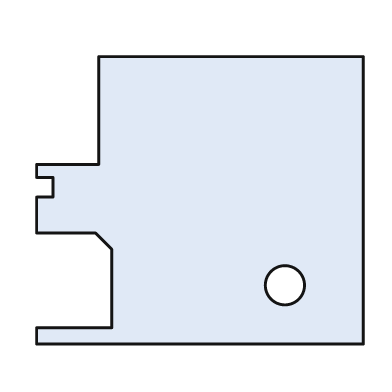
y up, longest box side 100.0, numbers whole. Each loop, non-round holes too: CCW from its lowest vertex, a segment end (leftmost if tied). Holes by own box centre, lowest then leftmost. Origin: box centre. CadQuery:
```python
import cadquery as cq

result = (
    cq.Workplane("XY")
    .moveTo(-50.0, -44.0)
    .lineTo(50.0, -44.0)
    .lineTo(50.0, 44.0)
    .lineTo(-31.0, 44.0)
    .lineTo(-31.0, 11.0)
    .lineTo(-50.0, 11.0)
    .lineTo(-50.0, 7.0)
    .lineTo(-45.0, 7.0)
    .lineTo(-45.0, 1.0)
    .lineTo(-50.0, 1.0)
    .lineTo(-50.0, -10.0)
    .lineTo(-32.0, -10.0)
    .lineTo(-27.0, -15.0)
    .lineTo(-27.0, -39.0)
    .lineTo(-50.0, -39.0)
    .close()
    .moveTo(26.0, -26.0)
    .circle(6.0)
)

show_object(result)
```